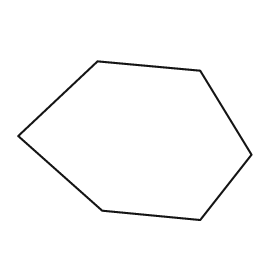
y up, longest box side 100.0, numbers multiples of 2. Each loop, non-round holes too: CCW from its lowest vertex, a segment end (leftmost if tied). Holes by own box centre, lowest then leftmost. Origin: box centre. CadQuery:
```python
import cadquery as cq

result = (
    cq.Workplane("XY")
    .moveTo(28.0, -34.0)
    .lineTo(50.0, -6.0)
    .lineTo(28.0, 30.0)
    .lineTo(-16.0, 34.0)
    .lineTo(-50.0, 2.0)
    .lineTo(-14.0, -30.0)
    .close()
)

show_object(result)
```